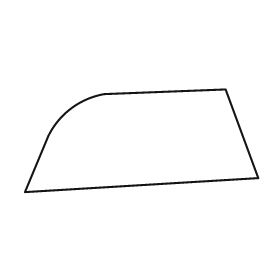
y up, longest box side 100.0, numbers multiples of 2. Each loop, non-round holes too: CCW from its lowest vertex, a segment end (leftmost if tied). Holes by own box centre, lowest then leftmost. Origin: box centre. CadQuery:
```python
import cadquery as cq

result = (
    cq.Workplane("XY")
    .moveTo(-50.0, -22.0)
    .lineTo(50.0, -16.0)
    .lineTo(36.0, 22.0)
    .lineTo(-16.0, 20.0)
    .threePointArc((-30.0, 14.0), (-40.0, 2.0))
    .close()
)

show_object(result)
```